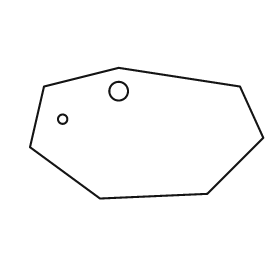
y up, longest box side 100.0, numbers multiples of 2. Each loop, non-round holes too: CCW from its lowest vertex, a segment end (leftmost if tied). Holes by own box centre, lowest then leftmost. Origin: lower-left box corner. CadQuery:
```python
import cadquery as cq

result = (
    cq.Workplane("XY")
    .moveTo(30.0, 0.0)
    .lineTo(76.0, 2.0)
    .lineTo(100.0, 26.0)
    .lineTo(90.0, 48.0)
    .lineTo(38.0, 56.0)
    .lineTo(6.0, 48.0)
    .lineTo(0.0, 22.0)
    .close()
    .moveTo(14.0, 34.0)
    .circle(2.0)
    .moveTo(38.0, 46.0)
    .circle(4.0)
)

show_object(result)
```